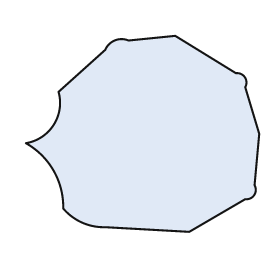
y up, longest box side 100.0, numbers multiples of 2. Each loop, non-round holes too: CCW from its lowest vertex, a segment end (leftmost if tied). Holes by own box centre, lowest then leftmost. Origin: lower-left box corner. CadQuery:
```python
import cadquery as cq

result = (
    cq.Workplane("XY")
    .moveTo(70.0, 0.0)
    .lineTo(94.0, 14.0)
    .threePointArc((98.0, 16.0), (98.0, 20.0))
    .lineTo(100.0, 42.0)
    .lineTo(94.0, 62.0)
    .threePointArc((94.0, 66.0), (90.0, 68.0))
    .lineTo(64.0, 84.0)
    .lineTo(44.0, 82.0)
    .threePointArc((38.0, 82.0), (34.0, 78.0))
    .lineTo(14.0, 60.0)
    .threePointArc((12.0, 46.0), (0.0, 38.0))
    .threePointArc((12.0, 26.0), (16.0, 10.0))
    .threePointArc((24.0, 4.0), (34.0, 2.0))
    .close()
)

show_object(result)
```